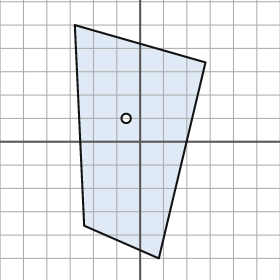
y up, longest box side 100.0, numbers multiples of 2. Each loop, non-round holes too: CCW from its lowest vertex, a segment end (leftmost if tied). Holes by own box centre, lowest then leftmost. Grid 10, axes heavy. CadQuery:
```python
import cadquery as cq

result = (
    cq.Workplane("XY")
    .moveTo(8.0, -50.0)
    .lineTo(28.0, 34.0)
    .lineTo(-28.0, 50.0)
    .lineTo(-24.0, -36.0)
    .close()
    .moveTo(-6.0, 10.0)
    .circle(2.0)
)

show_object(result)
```